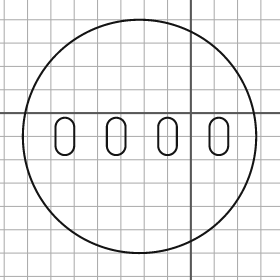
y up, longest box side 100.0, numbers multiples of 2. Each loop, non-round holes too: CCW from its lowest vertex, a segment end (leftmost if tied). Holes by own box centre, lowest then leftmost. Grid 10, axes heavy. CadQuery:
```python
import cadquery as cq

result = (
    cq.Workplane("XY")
    .moveTo(-22.0, -10.0)
    .circle(50.0)
    .moveTo(-58.0, -14.0)
    .threePointArc((-54.0, -18.0), (-50.0, -14.0))
    .lineTo(-50.0, -6.0)
    .threePointArc((-54.0, -2.0), (-58.0, -6.0))
    .close()
    .moveTo(-36.0, -14.0)
    .threePointArc((-32.0, -18.0), (-28.0, -14.0))
    .lineTo(-28.0, -6.0)
    .threePointArc((-32.0, -2.0), (-36.0, -6.0))
    .close()
    .moveTo(-14.0, -14.0)
    .threePointArc((-10.0, -18.0), (-6.0, -14.0))
    .lineTo(-6.0, -6.0)
    .threePointArc((-10.0, -2.0), (-14.0, -6.0))
    .close()
    .moveTo(8.0, -14.0)
    .threePointArc((12.0, -18.0), (16.0, -14.0))
    .lineTo(16.0, -6.0)
    .threePointArc((12.0, -2.0), (8.0, -6.0))
    .close()
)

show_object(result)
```